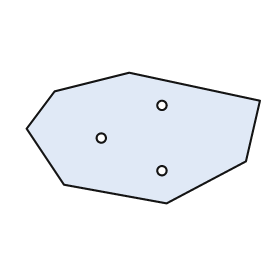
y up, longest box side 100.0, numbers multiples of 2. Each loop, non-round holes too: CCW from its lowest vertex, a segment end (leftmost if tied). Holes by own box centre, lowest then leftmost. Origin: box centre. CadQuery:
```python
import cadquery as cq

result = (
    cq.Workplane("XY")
    .moveTo(10.0, -28.0)
    .lineTo(44.0, -10.0)
    .lineTo(50.0, 16.0)
    .lineTo(-6.0, 28.0)
    .lineTo(-38.0, 20.0)
    .lineTo(-50.0, 4.0)
    .lineTo(-34.0, -20.0)
    .close()
    .moveTo(8.0, -14.0)
    .circle(2.0)
    .moveTo(-18.0, 0.0)
    .circle(2.0)
    .moveTo(8.0, 14.0)
    .circle(2.0)
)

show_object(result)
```